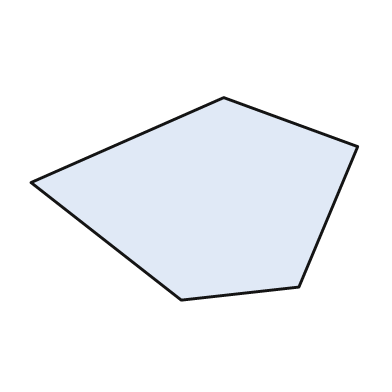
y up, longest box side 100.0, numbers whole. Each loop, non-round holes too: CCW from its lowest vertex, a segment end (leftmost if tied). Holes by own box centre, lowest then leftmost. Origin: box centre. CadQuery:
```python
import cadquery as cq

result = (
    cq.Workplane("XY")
    .moveTo(-4.0, -31.0)
    .lineTo(32.0, -27.0)
    .lineTo(50.0, 16.0)
    .lineTo(9.0, 31.0)
    .lineTo(-50.0, 5.0)
    .close()
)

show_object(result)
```